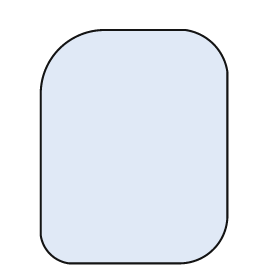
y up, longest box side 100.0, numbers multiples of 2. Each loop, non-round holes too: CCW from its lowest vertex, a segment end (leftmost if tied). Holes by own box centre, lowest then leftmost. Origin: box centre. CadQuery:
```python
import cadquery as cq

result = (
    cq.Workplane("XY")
    .moveTo(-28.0, -50.0)
    .lineTo(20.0, -50.0)
    .threePointArc((34.0, -44.0), (40.0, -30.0))
    .lineTo(40.0, 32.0)
    .threePointArc((34.0, 44.0), (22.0, 50.0))
    .lineTo(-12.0, 50.0)
    .threePointArc((-32.0, 42.0), (-40.0, 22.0))
    .lineTo(-40.0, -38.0)
    .threePointArc((-36.0, -46.0), (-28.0, -50.0))
    .close()
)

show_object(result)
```